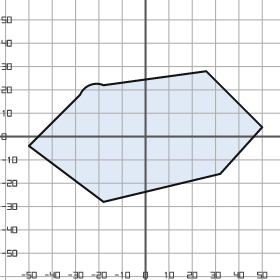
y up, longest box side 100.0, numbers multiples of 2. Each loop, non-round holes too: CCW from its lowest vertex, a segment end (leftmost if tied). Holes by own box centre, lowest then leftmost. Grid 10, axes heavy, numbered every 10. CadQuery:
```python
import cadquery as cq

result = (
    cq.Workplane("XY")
    .moveTo(-18.0, -28.0)
    .lineTo(32.0, -16.0)
    .lineTo(50.0, 4.0)
    .lineTo(26.0, 28.0)
    .lineTo(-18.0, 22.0)
    .threePointArc((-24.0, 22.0), (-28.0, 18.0))
    .lineTo(-50.0, -4.0)
    .close()
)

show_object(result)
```